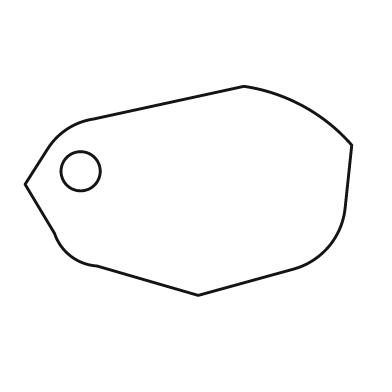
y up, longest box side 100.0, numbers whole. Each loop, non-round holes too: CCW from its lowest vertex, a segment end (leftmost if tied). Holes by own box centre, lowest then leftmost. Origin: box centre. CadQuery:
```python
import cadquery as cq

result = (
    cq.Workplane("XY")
    .moveTo(3.0, -32.0)
    .lineTo(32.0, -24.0)
    .threePointArc((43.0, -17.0), (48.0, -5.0))
    .lineTo(50.0, 14.0)
    .threePointArc((35.0, 26.0), (17.0, 32.0))
    .lineTo(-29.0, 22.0)
    .threePointArc((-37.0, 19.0), (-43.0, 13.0))
    .lineTo(-50.0, 2.0)
    .lineTo(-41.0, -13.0)
    .threePointArc((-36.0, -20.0), (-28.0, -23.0))
    .close()
    .moveTo(-33.0, 6.0)
    .circle(6.0)
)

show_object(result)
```